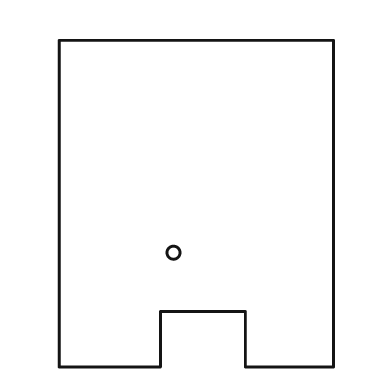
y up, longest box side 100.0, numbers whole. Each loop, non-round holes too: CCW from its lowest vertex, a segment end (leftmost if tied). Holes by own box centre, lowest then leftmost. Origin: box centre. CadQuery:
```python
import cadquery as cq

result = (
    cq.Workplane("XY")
    .moveTo(-42.0, -50.0)
    .lineTo(-11.0, -50.0)
    .lineTo(-11.0, -33.0)
    .lineTo(15.0, -33.0)
    .lineTo(15.0, -50.0)
    .lineTo(42.0, -50.0)
    .lineTo(42.0, 50.0)
    .lineTo(-42.0, 50.0)
    .close()
    .moveTo(-7.0, -15.0)
    .circle(2.0)
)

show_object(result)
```